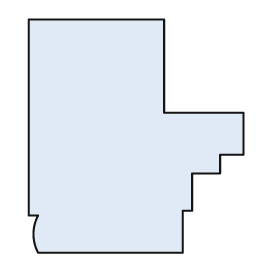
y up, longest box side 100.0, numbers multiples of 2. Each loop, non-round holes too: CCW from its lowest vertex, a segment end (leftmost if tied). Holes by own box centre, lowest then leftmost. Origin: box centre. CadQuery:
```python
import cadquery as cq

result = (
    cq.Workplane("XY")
    .moveTo(-42.0, -50.0)
    .lineTo(20.0, -50.0)
    .lineTo(20.0, -32.0)
    .lineTo(24.0, -32.0)
    .lineTo(24.0, -16.0)
    .lineTo(36.0, -16.0)
    .lineTo(36.0, -8.0)
    .lineTo(46.0, -8.0)
    .lineTo(46.0, 10.0)
    .lineTo(12.0, 10.0)
    .lineTo(12.0, 50.0)
    .lineTo(-46.0, 50.0)
    .lineTo(-46.0, -34.0)
    .lineTo(-42.0, -34.0)
    .threePointArc((-44.0, -42.0), (-42.0, -50.0))
    .close()
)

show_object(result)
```